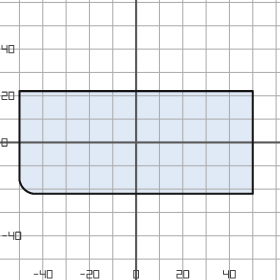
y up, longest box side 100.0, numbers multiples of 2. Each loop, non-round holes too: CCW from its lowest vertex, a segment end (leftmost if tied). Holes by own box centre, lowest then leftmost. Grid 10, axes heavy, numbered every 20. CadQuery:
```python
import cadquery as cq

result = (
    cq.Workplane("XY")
    .moveTo(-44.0, -22.0)
    .lineTo(50.0, -22.0)
    .lineTo(50.0, 22.0)
    .lineTo(-50.0, 22.0)
    .lineTo(-50.0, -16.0)
    .threePointArc((-48.0, -20.0), (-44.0, -22.0))
    .close()
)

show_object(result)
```